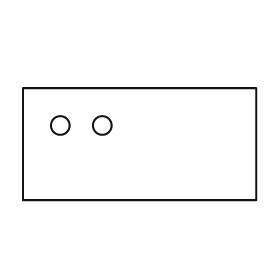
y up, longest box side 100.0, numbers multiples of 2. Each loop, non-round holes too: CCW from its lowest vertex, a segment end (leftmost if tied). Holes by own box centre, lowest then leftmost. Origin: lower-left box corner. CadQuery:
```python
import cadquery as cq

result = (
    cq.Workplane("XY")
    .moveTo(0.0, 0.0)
    .lineTo(100.0, 0.0)
    .lineTo(100.0, 48.0)
    .lineTo(0.0, 48.0)
    .close()
    .moveTo(16.0, 32.0)
    .circle(4.0)
    .moveTo(34.0, 32.0)
    .circle(4.0)
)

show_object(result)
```